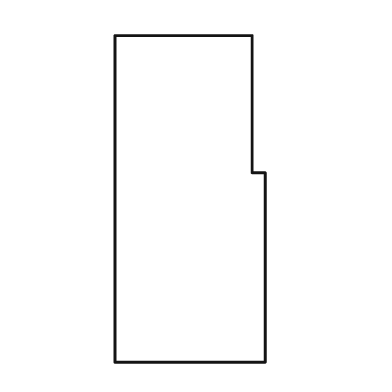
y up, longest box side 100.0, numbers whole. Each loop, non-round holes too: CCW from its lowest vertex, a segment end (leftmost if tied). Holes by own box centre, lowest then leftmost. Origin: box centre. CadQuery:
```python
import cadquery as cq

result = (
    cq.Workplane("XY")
    .moveTo(-23.0, -50.0)
    .lineTo(23.0, -50.0)
    .lineTo(23.0, 8.0)
    .lineTo(19.0, 8.0)
    .lineTo(19.0, 50.0)
    .lineTo(-23.0, 50.0)
    .close()
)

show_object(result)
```